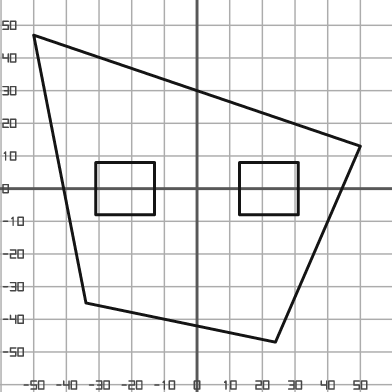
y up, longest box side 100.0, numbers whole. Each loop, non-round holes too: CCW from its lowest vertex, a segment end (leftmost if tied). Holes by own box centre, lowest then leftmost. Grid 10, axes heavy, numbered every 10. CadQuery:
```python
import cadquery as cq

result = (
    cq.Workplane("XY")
    .moveTo(24.0, -47.0)
    .lineTo(50.0, 13.0)
    .lineTo(-50.0, 47.0)
    .lineTo(-34.0, -35.0)
    .close()
    .moveTo(-31.0, -8.0)
    .lineTo(-13.0, -8.0)
    .lineTo(-13.0, 8.0)
    .lineTo(-31.0, 8.0)
    .close()
    .moveTo(13.0, -8.0)
    .lineTo(31.0, -8.0)
    .lineTo(31.0, 8.0)
    .lineTo(13.0, 8.0)
    .close()
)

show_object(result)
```